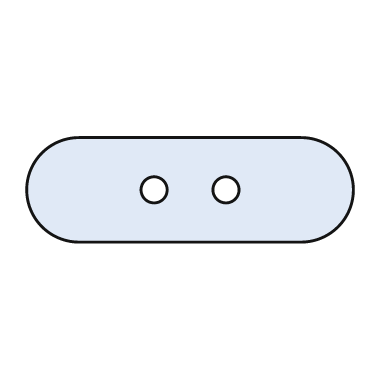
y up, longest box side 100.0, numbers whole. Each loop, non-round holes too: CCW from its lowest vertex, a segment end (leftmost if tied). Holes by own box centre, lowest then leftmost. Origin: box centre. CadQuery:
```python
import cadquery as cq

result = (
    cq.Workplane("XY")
    .moveTo(-34.0, -16.0)
    .lineTo(34.0, -16.0)
    .threePointArc((50.0, 0.0), (34.0, 16.0))
    .lineTo(-34.0, 16.0)
    .threePointArc((-50.0, 0.0), (-34.0, -16.0))
    .close()
    .moveTo(-11.0, 0.0)
    .circle(4.0)
    .moveTo(11.0, 0.0)
    .circle(4.0)
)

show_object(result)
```